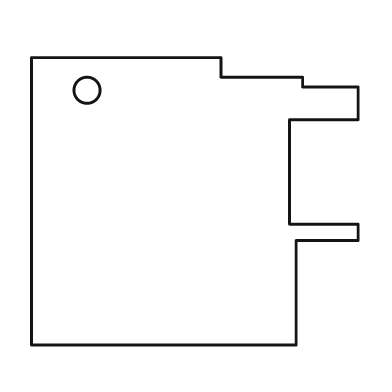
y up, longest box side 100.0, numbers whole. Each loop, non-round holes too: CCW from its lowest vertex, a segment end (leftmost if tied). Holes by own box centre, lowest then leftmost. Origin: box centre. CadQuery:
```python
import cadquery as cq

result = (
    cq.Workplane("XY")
    .moveTo(-50.0, -44.0)
    .lineTo(31.0, -44.0)
    .lineTo(31.0, -12.0)
    .lineTo(50.0, -12.0)
    .lineTo(50.0, -7.0)
    .lineTo(29.0, -7.0)
    .lineTo(29.0, 25.0)
    .lineTo(50.0, 25.0)
    .lineTo(50.0, 35.0)
    .lineTo(33.0, 35.0)
    .lineTo(33.0, 38.0)
    .lineTo(8.0, 38.0)
    .lineTo(8.0, 44.0)
    .lineTo(-50.0, 44.0)
    .close()
    .moveTo(-33.0, 34.0)
    .circle(4.0)
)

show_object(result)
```